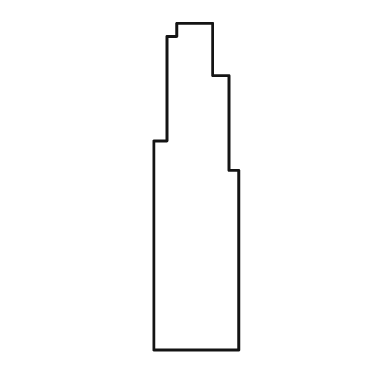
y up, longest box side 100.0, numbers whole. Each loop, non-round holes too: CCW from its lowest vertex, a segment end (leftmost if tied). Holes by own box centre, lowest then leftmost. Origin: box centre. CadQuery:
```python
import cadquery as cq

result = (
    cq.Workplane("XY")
    .moveTo(-13.0, -50.0)
    .lineTo(13.0, -50.0)
    .lineTo(13.0, 5.0)
    .lineTo(10.0, 5.0)
    .lineTo(10.0, 34.0)
    .lineTo(5.0, 34.0)
    .lineTo(5.0, 50.0)
    .lineTo(-6.0, 50.0)
    .lineTo(-6.0, 46.0)
    .lineTo(-9.0, 46.0)
    .lineTo(-9.0, 14.0)
    .lineTo(-13.0, 14.0)
    .close()
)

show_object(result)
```